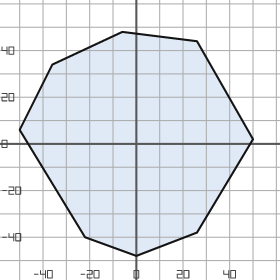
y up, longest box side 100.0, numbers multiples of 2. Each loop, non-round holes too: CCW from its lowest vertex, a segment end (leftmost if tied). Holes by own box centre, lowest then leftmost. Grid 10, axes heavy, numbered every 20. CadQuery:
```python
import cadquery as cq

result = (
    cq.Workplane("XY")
    .moveTo(0.0, -48.0)
    .lineTo(26.0, -38.0)
    .lineTo(50.0, 2.0)
    .lineTo(26.0, 44.0)
    .lineTo(-6.0, 48.0)
    .lineTo(-36.0, 34.0)
    .lineTo(-50.0, 6.0)
    .lineTo(-22.0, -40.0)
    .close()
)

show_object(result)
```